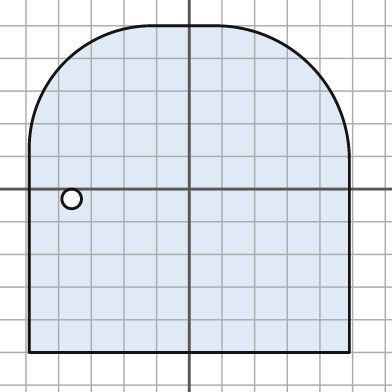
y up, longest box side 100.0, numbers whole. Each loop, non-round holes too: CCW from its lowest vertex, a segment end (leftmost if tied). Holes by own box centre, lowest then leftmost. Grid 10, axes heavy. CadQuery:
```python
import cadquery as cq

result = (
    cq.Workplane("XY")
    .moveTo(-49.0, -50.0)
    .lineTo(49.0, -50.0)
    .lineTo(49.0, 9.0)
    .threePointArc((37.0, 38.0), (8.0, 50.0))
    .lineTo(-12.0, 50.0)
    .threePointArc((-38.0, 39.0), (-49.0, 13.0))
    .close()
    .moveTo(-36.0, -3.0)
    .circle(3.0)
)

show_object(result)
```